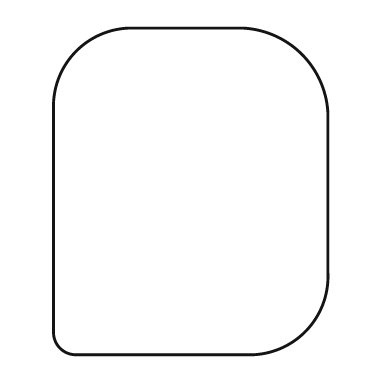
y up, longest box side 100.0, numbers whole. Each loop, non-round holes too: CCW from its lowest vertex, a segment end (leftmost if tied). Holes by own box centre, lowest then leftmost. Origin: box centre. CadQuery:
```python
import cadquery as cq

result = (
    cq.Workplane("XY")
    .moveTo(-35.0, -50.0)
    .lineTo(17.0, -50.0)
    .threePointArc((35.0, -43.0), (42.0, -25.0))
    .lineTo(42.0, 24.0)
    .threePointArc((34.0, 42.0), (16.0, 50.0))
    .lineTo(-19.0, 50.0)
    .threePointArc((-35.0, 43.0), (-42.0, 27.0))
    .lineTo(-42.0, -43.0)
    .threePointArc((-40.0, -48.0), (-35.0, -50.0))
    .close()
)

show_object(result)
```